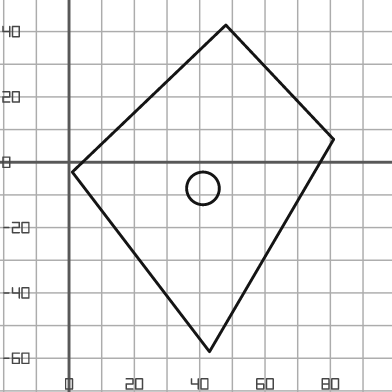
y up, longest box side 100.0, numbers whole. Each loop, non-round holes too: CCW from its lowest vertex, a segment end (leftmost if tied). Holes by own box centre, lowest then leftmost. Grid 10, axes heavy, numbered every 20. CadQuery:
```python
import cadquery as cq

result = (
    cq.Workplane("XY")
    .moveTo(43.0, -58.0)
    .lineTo(81.0, 7.0)
    .lineTo(48.0, 42.0)
    .lineTo(1.0, -3.0)
    .close()
    .moveTo(41.0, -8.0)
    .circle(5.0)
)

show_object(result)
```